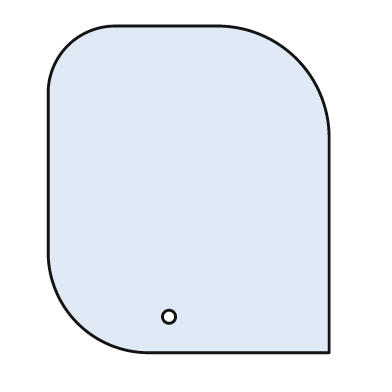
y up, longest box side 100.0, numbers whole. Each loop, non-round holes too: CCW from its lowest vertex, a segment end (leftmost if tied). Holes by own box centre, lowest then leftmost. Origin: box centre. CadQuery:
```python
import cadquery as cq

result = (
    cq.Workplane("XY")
    .moveTo(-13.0, -50.0)
    .lineTo(43.0, -50.0)
    .lineTo(43.0, 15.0)
    .threePointArc((33.0, 40.0), (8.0, 50.0))
    .lineTo(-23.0, 50.0)
    .threePointArc((-37.0, 44.0), (-43.0, 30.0))
    .lineTo(-43.0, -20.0)
    .threePointArc((-34.0, -41.0), (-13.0, -50.0))
    .close()
    .moveTo(-6.0, -39.0)
    .circle(2.0)
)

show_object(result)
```